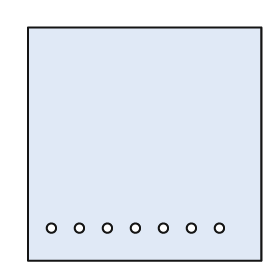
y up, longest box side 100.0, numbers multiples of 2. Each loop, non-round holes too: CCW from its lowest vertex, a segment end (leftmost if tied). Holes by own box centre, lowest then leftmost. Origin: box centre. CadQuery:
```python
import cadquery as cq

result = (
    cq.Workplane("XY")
    .moveTo(-50.0, -50.0)
    .lineTo(50.0, -50.0)
    .lineTo(50.0, 50.0)
    .lineTo(-50.0, 50.0)
    .close()
    .moveTo(-40.0, -36.0)
    .circle(2.0)
    .moveTo(-28.0, -36.0)
    .circle(2.0)
    .moveTo(-16.0, -36.0)
    .circle(2.0)
    .moveTo(-4.0, -36.0)
    .circle(2.0)
    .moveTo(8.0, -36.0)
    .circle(2.0)
    .moveTo(20.0, -36.0)
    .circle(2.0)
    .moveTo(32.0, -36.0)
    .circle(2.0)
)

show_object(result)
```